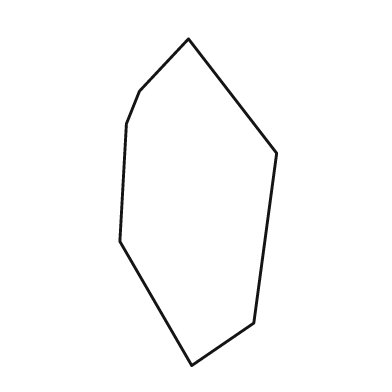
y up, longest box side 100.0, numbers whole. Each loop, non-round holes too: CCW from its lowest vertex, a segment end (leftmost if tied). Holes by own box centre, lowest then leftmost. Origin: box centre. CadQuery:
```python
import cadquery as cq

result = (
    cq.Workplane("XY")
    .moveTo(-2.0, -50.0)
    .lineTo(17.0, -37.0)
    .lineTo(24.0, 15.0)
    .lineTo(-3.0, 50.0)
    .lineTo(-18.0, 34.0)
    .lineTo(-22.0, 24.0)
    .lineTo(-24.0, -12.0)
    .close()
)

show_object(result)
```